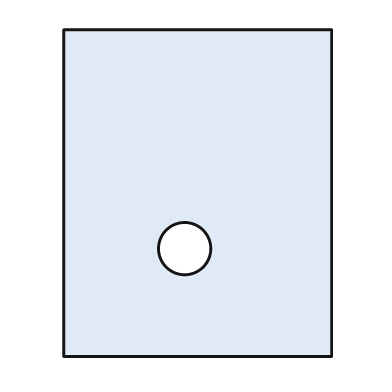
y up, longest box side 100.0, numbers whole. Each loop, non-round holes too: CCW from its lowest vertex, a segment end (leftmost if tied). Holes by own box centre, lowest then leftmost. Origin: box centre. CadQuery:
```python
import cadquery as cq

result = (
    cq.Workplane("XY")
    .moveTo(-41.0, -50.0)
    .lineTo(41.0, -50.0)
    .lineTo(41.0, 50.0)
    .lineTo(-41.0, 50.0)
    .close()
    .moveTo(-4.0, -17.0)
    .circle(8.0)
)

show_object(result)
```